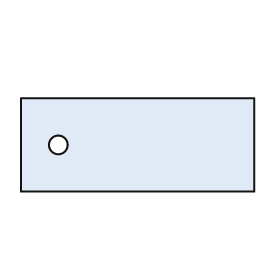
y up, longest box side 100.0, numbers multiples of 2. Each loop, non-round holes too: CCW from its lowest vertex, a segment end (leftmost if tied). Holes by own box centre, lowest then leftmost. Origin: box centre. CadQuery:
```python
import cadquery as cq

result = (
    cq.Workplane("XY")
    .moveTo(-50.0, -20.0)
    .lineTo(50.0, -20.0)
    .lineTo(50.0, 20.0)
    .lineTo(-50.0, 20.0)
    .close()
    .moveTo(-34.0, 0.0)
    .circle(4.0)
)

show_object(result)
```